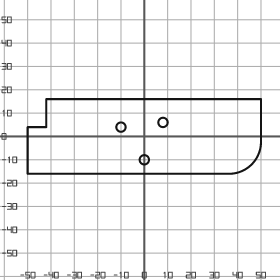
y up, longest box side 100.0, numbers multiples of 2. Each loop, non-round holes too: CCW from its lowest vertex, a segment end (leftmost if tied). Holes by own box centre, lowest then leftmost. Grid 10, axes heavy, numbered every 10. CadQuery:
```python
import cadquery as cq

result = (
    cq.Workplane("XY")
    .moveTo(-50.0, -16.0)
    .lineTo(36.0, -16.0)
    .threePointArc((46.0, -12.0), (50.0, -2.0))
    .lineTo(50.0, 16.0)
    .lineTo(-42.0, 16.0)
    .lineTo(-42.0, 4.0)
    .lineTo(-50.0, 4.0)
    .close()
    .moveTo(0.0, -10.0)
    .circle(2.0)
    .moveTo(-10.0, 4.0)
    .circle(2.0)
    .moveTo(8.0, 6.0)
    .circle(2.0)
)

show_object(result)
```